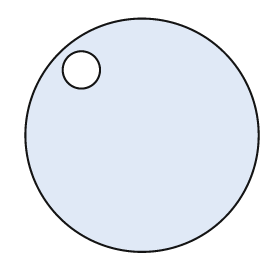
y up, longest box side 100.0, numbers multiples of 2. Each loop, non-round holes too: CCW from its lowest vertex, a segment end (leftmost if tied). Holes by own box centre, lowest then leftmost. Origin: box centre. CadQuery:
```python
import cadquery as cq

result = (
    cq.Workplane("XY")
    .moveTo(0.0, 0.0)
    .circle(50.0)
    .moveTo(-26.0, 28.0)
    .circle(8.0)
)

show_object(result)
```